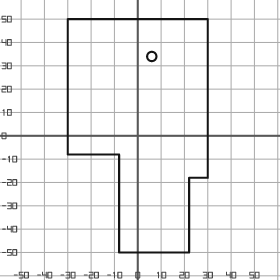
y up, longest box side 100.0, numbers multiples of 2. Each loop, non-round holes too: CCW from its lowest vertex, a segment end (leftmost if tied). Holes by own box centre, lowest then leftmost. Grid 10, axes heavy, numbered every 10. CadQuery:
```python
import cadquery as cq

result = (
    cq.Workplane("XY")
    .moveTo(-8.0, -50.0)
    .lineTo(22.0, -50.0)
    .lineTo(22.0, -18.0)
    .lineTo(30.0, -18.0)
    .lineTo(30.0, 50.0)
    .lineTo(-30.0, 50.0)
    .lineTo(-30.0, -8.0)
    .lineTo(-8.0, -8.0)
    .close()
    .moveTo(6.0, 34.0)
    .circle(2.0)
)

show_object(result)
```